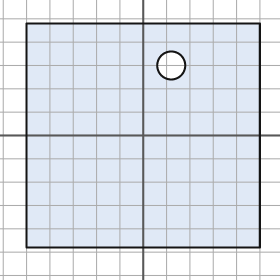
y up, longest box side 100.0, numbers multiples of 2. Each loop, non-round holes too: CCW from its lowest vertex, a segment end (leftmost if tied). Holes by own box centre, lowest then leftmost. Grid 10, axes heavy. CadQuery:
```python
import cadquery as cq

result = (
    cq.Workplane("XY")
    .moveTo(-50.0, -48.0)
    .lineTo(50.0, -48.0)
    .lineTo(50.0, 48.0)
    .lineTo(-50.0, 48.0)
    .close()
    .moveTo(12.0, 30.0)
    .circle(6.0)
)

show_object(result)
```